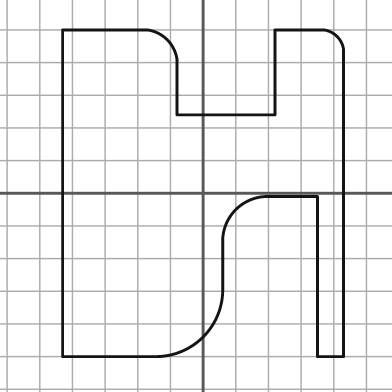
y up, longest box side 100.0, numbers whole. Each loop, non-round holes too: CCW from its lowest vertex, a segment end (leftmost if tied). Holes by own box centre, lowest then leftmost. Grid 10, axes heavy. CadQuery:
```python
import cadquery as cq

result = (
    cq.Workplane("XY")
    .moveTo(-43.0, -50.0)
    .lineTo(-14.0, -50.0)
    .threePointArc((0.0, -44.0), (6.0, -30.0))
    .lineTo(6.0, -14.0)
    .threePointArc((10.0, -5.0), (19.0, -1.0))
    .lineTo(35.0, -1.0)
    .lineTo(35.0, -50.0)
    .lineTo(43.0, -50.0)
    .lineTo(43.0, 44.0)
    .threePointArc((41.0, 48.0), (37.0, 50.0))
    .lineTo(22.0, 50.0)
    .lineTo(22.0, 24.0)
    .lineTo(-8.0, 24.0)
    .lineTo(-8.0, 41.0)
    .threePointArc((-11.0, 47.0), (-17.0, 50.0))
    .lineTo(-43.0, 50.0)
    .close()
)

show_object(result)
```